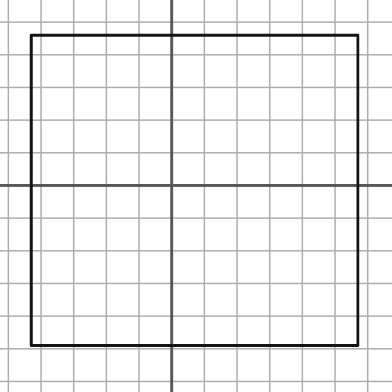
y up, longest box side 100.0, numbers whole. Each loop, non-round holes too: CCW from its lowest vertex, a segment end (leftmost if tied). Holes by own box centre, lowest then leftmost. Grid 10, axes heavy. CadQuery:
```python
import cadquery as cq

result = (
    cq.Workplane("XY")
    .moveTo(-43.0, -49.0)
    .lineTo(57.0, -49.0)
    .lineTo(57.0, 46.0)
    .lineTo(-43.0, 46.0)
    .close()
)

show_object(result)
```